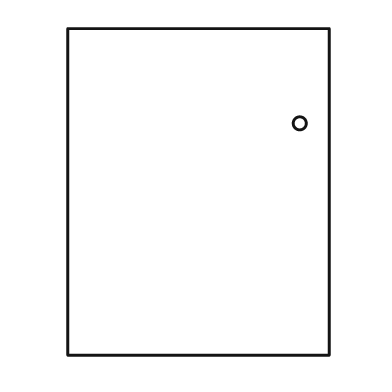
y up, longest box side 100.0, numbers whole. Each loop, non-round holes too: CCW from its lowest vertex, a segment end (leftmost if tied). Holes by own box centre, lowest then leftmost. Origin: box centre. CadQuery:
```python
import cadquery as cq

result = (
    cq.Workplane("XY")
    .moveTo(-40.0, -50.0)
    .lineTo(40.0, -50.0)
    .lineTo(40.0, 50.0)
    .lineTo(-40.0, 50.0)
    .close()
    .moveTo(31.0, 21.0)
    .circle(2.0)
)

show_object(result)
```